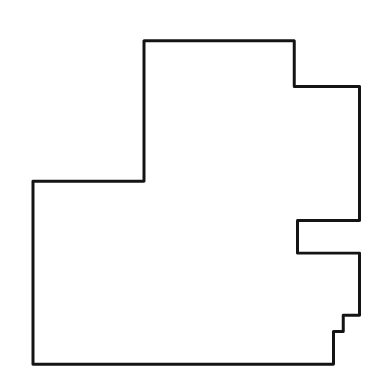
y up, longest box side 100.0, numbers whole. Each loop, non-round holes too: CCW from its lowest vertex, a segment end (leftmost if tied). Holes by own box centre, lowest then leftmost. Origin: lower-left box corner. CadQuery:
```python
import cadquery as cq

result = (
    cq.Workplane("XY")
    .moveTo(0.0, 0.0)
    .lineTo(92.0, 0.0)
    .lineTo(92.0, 10.0)
    .lineTo(95.0, 10.0)
    .lineTo(95.0, 15.0)
    .lineTo(100.0, 15.0)
    .lineTo(100.0, 34.0)
    .lineTo(81.0, 34.0)
    .lineTo(81.0, 44.0)
    .lineTo(100.0, 44.0)
    .lineTo(100.0, 85.0)
    .lineTo(80.0, 85.0)
    .lineTo(80.0, 99.0)
    .lineTo(34.0, 99.0)
    .lineTo(34.0, 56.0)
    .lineTo(0.0, 56.0)
    .close()
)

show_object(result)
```